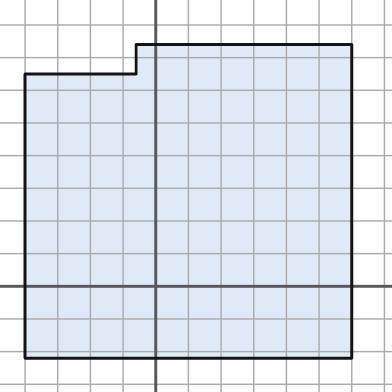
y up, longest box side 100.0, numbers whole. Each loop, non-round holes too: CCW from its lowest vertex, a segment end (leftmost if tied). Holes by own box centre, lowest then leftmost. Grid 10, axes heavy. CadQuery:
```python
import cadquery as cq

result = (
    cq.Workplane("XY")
    .moveTo(-40.0, -22.0)
    .lineTo(60.0, -22.0)
    .lineTo(60.0, 74.0)
    .lineTo(-6.0, 74.0)
    .lineTo(-6.0, 65.0)
    .lineTo(-40.0, 65.0)
    .close()
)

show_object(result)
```